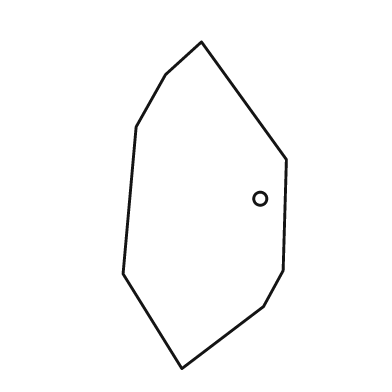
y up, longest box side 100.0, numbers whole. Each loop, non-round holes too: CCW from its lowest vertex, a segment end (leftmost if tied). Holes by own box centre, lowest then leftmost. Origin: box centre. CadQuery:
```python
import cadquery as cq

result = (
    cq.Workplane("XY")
    .moveTo(-7.0, -50.0)
    .lineTo(18.0, -31.0)
    .lineTo(24.0, -20.0)
    .lineTo(25.0, 14.0)
    .lineTo(-1.0, 50.0)
    .lineTo(-12.0, 40.0)
    .lineTo(-21.0, 24.0)
    .lineTo(-25.0, -21.0)
    .close()
    .moveTo(17.0, 2.0)
    .circle(2.0)
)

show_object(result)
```